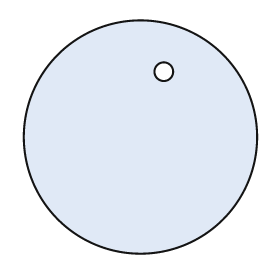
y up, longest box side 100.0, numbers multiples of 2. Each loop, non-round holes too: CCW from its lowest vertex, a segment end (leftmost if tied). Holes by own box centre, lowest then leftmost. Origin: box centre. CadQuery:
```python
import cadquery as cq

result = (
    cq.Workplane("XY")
    .moveTo(0.0, 0.0)
    .circle(50.0)
    .moveTo(10.0, 28.0)
    .circle(4.0)
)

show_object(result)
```